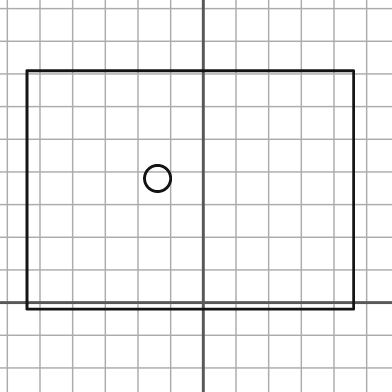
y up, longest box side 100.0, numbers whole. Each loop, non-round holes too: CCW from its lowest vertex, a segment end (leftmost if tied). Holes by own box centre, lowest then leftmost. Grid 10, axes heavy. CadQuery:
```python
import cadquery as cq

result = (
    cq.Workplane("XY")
    .moveTo(-54.0, -2.0)
    .lineTo(46.0, -2.0)
    .lineTo(46.0, 71.0)
    .lineTo(-54.0, 71.0)
    .close()
    .moveTo(-14.0, 38.0)
    .circle(4.0)
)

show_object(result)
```